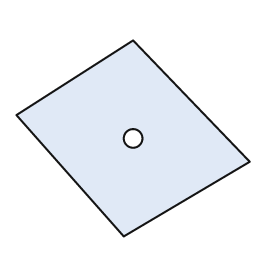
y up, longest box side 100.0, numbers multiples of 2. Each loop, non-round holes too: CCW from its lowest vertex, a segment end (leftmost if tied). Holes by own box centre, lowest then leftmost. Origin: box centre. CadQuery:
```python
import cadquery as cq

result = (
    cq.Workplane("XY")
    .moveTo(-4.0, -42.0)
    .lineTo(50.0, -10.0)
    .lineTo(0.0, 42.0)
    .lineTo(-50.0, 10.0)
    .close()
    .moveTo(0.0, 0.0)
    .circle(4.0)
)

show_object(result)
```